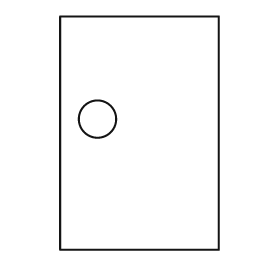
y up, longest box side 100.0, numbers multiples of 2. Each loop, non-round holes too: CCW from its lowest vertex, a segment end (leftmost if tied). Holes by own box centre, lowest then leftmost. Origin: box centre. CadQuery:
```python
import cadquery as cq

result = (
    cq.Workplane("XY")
    .moveTo(-34.0, -50.0)
    .lineTo(34.0, -50.0)
    .lineTo(34.0, 50.0)
    .lineTo(-34.0, 50.0)
    .close()
    .moveTo(-18.0, 6.0)
    .circle(8.0)
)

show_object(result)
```